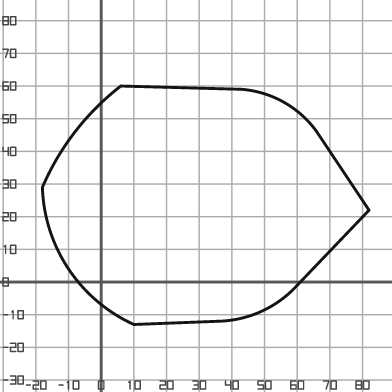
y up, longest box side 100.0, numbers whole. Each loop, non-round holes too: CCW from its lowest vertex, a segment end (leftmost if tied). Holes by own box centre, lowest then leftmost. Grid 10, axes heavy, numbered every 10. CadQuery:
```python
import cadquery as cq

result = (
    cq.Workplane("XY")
    .moveTo(10.0, -13.0)
    .lineTo(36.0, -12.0)
    .threePointArc((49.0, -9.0), (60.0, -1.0))
    .lineTo(82.0, 22.0)
    .lineTo(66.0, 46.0)
    .threePointArc((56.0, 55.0), (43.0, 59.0))
    .lineTo(6.0, 60.0)
    .threePointArc((-8.0, 46.0), (-18.0, 29.0))
    .threePointArc((-10.0, 4.0), (10.0, -13.0))
    .close()
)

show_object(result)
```